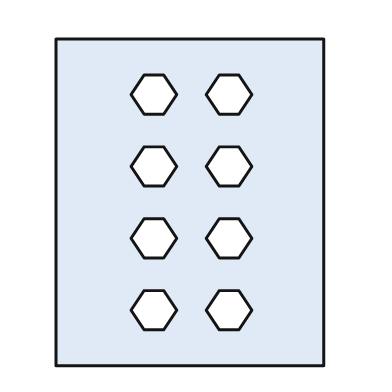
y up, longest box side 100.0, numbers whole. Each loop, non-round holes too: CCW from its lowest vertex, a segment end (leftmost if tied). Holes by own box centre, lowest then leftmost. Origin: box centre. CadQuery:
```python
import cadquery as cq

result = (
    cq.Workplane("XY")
    .moveTo(-41.0, -50.0)
    .lineTo(41.0, -50.0)
    .lineTo(41.0, 50.0)
    .lineTo(-41.0, 50.0)
    .close()
    .moveTo(-14.0, -39.0)
    .lineTo(-8.0, -39.0)
    .lineTo(-4.0, -33.0)
    .lineTo(-8.0, -27.0)
    .lineTo(-14.0, -27.0)
    .lineTo(-18.0, -33.0)
    .close()
    .moveTo(9.0, -39.0)
    .lineTo(15.0, -39.0)
    .lineTo(19.0, -33.0)
    .lineTo(15.0, -27.0)
    .lineTo(9.0, -27.0)
    .lineTo(5.0, -33.0)
    .close()
    .moveTo(-14.0, -17.0)
    .lineTo(-8.0, -17.0)
    .lineTo(-4.0, -11.0)
    .lineTo(-8.0, -5.0)
    .lineTo(-14.0, -5.0)
    .lineTo(-18.0, -11.0)
    .close()
    .moveTo(9.0, -17.0)
    .lineTo(15.0, -17.0)
    .lineTo(19.0, -11.0)
    .lineTo(15.0, -5.0)
    .lineTo(9.0, -5.0)
    .lineTo(5.0, -11.0)
    .close()
    .moveTo(-14.0, 5.0)
    .lineTo(-8.0, 5.0)
    .lineTo(-4.0, 11.0)
    .lineTo(-8.0, 17.0)
    .lineTo(-14.0, 17.0)
    .lineTo(-18.0, 11.0)
    .close()
    .moveTo(9.0, 5.0)
    .lineTo(15.0, 5.0)
    .lineTo(19.0, 11.0)
    .lineTo(15.0, 17.0)
    .lineTo(9.0, 17.0)
    .lineTo(5.0, 11.0)
    .close()
    .moveTo(-14.0, 27.0)
    .lineTo(-8.0, 27.0)
    .lineTo(-4.0, 33.0)
    .lineTo(-8.0, 39.0)
    .lineTo(-14.0, 39.0)
    .lineTo(-18.0, 33.0)
    .close()
    .moveTo(9.0, 27.0)
    .lineTo(15.0, 27.0)
    .lineTo(19.0, 33.0)
    .lineTo(15.0, 39.0)
    .lineTo(9.0, 39.0)
    .lineTo(5.0, 33.0)
    .close()
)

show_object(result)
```